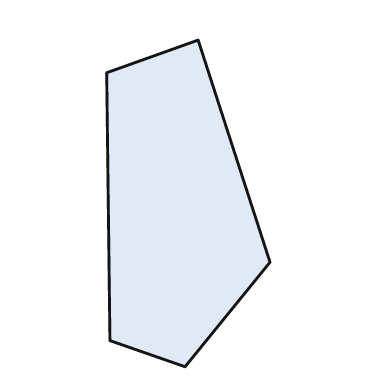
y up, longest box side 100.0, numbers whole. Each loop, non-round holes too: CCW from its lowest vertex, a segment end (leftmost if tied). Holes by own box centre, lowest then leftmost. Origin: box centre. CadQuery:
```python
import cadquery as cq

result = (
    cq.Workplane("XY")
    .moveTo(-1.0, -50.0)
    .lineTo(25.0, -18.0)
    .lineTo(3.0, 50.0)
    .lineTo(-25.0, 40.0)
    .lineTo(-24.0, -42.0)
    .close()
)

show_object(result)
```